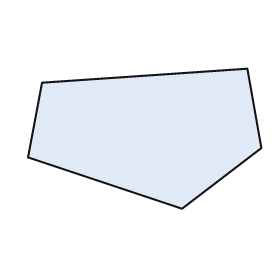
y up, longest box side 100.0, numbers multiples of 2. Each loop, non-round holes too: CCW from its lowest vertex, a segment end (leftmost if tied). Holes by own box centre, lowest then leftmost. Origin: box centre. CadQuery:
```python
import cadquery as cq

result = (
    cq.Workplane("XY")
    .moveTo(16.0, -30.0)
    .lineTo(50.0, -4.0)
    .lineTo(44.0, 30.0)
    .lineTo(-44.0, 24.0)
    .lineTo(-50.0, -8.0)
    .close()
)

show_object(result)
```